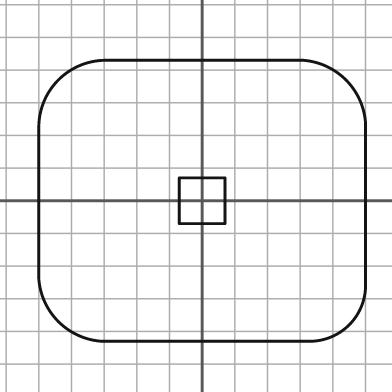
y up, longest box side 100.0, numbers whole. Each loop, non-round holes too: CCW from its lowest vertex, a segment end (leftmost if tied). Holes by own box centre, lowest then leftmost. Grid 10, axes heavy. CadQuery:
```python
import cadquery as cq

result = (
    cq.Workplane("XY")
    .moveTo(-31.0, -43.0)
    .lineTo(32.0, -43.0)
    .threePointArc((45.0, -38.0), (50.0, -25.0))
    .lineTo(50.0, 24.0)
    .threePointArc((44.0, 37.0), (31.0, 43.0))
    .lineTo(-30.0, 43.0)
    .threePointArc((-44.0, 37.0), (-50.0, 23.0))
    .lineTo(-50.0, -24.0)
    .threePointArc((-44.0, -37.0), (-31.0, -43.0))
    .close()
    .moveTo(-7.0, -7.0)
    .lineTo(7.0, -7.0)
    .lineTo(7.0, 7.0)
    .lineTo(-7.0, 7.0)
    .close()
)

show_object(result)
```